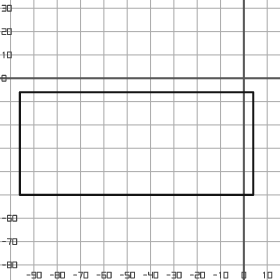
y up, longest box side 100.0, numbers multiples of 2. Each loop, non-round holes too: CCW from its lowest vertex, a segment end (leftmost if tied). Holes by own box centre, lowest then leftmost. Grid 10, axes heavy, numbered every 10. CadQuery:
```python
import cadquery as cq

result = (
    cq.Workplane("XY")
    .moveTo(-96.0, -50.0)
    .lineTo(4.0, -50.0)
    .lineTo(4.0, -6.0)
    .lineTo(-96.0, -6.0)
    .close()
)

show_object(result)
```